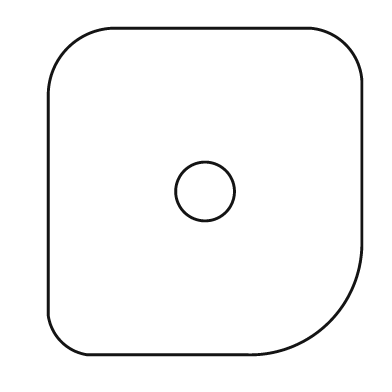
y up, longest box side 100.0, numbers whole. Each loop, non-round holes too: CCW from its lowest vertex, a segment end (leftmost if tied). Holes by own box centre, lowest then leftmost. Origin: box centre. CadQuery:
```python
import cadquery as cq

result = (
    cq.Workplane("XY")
    .moveTo(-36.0, -50.0)
    .lineTo(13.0, -50.0)
    .threePointArc((38.0, -40.0), (48.0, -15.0))
    .lineTo(48.0, 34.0)
    .threePointArc((43.0, 45.0), (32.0, 50.0))
    .lineTo(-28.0, 50.0)
    .threePointArc((-42.0, 44.0), (-48.0, 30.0))
    .lineTo(-48.0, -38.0)
    .threePointArc((-44.0, -46.0), (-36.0, -50.0))
    .close()
    .moveTo(0.0, 0.0)
    .circle(9.0)
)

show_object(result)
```